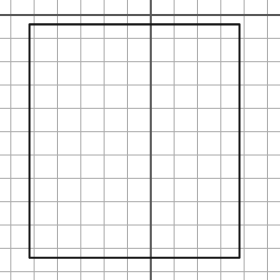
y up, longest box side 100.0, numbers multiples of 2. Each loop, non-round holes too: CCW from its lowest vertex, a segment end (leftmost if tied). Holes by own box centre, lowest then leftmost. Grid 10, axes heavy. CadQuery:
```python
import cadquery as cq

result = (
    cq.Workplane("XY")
    .moveTo(-52.0, -104.0)
    .lineTo(38.0, -104.0)
    .lineTo(38.0, -4.0)
    .lineTo(-52.0, -4.0)
    .close()
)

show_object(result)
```